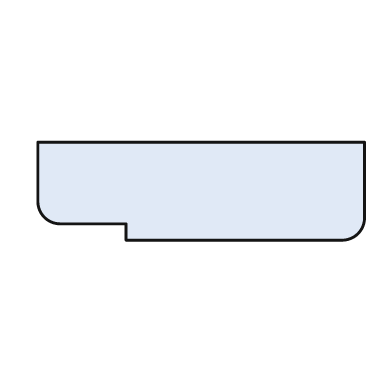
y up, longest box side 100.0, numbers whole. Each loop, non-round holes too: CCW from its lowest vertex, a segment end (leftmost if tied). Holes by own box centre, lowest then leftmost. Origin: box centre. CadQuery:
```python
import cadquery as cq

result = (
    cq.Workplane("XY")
    .moveTo(-23.0, -15.0)
    .lineTo(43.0, -15.0)
    .threePointArc((48.0, -13.0), (50.0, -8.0))
    .lineTo(50.0, 15.0)
    .lineTo(-50.0, 15.0)
    .lineTo(-50.0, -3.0)
    .threePointArc((-48.0, -8.0), (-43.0, -10.0))
    .lineTo(-23.0, -10.0)
    .close()
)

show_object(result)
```